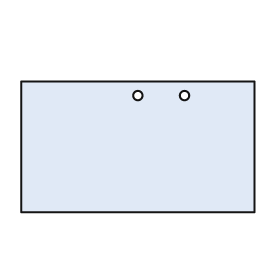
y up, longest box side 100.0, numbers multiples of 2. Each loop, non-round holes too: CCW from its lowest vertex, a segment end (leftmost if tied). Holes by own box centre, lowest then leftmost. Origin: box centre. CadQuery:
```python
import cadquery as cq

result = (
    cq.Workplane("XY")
    .moveTo(-50.0, -28.0)
    .lineTo(50.0, -28.0)
    .lineTo(50.0, 28.0)
    .lineTo(-50.0, 28.0)
    .close()
    .moveTo(0.0, 22.0)
    .circle(2.0)
    .moveTo(20.0, 22.0)
    .circle(2.0)
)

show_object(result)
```